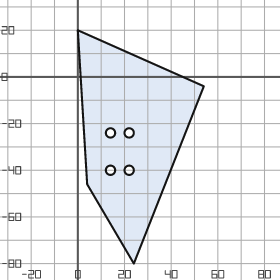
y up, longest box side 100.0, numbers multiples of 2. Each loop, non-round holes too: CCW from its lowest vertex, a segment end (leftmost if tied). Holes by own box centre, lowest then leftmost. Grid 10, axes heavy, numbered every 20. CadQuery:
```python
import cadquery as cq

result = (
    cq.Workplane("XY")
    .moveTo(24.0, -80.0)
    .lineTo(54.0, -4.0)
    .lineTo(0.0, 20.0)
    .lineTo(4.0, -46.0)
    .close()
    .moveTo(14.0, -40.0)
    .circle(2.0)
    .moveTo(22.0, -40.0)
    .circle(2.0)
    .moveTo(14.0, -24.0)
    .circle(2.0)
    .moveTo(22.0, -24.0)
    .circle(2.0)
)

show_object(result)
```